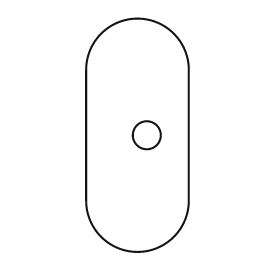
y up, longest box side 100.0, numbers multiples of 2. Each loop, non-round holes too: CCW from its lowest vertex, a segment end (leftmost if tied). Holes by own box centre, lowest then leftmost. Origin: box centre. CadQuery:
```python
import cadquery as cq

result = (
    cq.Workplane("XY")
    .moveTo(-22.0, -28.0)
    .threePointArc((0.0, -50.0), (22.0, -28.0))
    .lineTo(22.0, 28.0)
    .threePointArc((0.0, 50.0), (-22.0, 28.0))
    .close()
    .moveTo(4.0, 0.0)
    .circle(6.0)
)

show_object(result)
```